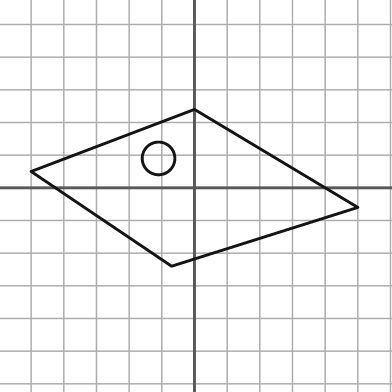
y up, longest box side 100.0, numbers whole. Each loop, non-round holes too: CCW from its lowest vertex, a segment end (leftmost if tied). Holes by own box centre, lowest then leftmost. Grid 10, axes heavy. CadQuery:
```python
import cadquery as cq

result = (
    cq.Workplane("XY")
    .moveTo(-7.0, -24.0)
    .lineTo(50.0, -6.0)
    .lineTo(0.0, 24.0)
    .lineTo(-50.0, 5.0)
    .close()
    .moveTo(-11.0, 9.0)
    .circle(5.0)
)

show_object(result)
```